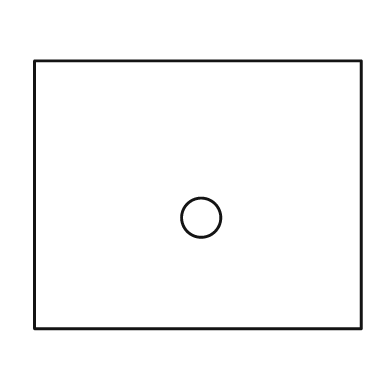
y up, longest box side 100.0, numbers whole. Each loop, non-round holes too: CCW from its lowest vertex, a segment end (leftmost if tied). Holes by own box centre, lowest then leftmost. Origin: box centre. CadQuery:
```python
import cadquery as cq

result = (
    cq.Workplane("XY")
    .moveTo(-50.0, -41.0)
    .lineTo(50.0, -41.0)
    .lineTo(50.0, 41.0)
    .lineTo(-50.0, 41.0)
    .close()
    .moveTo(1.0, -7.0)
    .circle(6.0)
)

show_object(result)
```